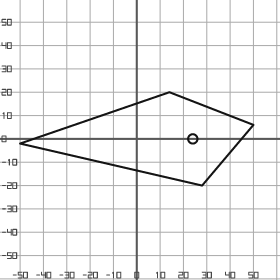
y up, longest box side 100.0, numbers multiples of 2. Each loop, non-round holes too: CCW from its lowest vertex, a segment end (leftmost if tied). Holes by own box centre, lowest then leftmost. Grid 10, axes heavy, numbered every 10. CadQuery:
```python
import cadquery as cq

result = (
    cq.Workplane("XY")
    .moveTo(28.0, -20.0)
    .lineTo(50.0, 6.0)
    .lineTo(14.0, 20.0)
    .lineTo(-50.0, -2.0)
    .close()
    .moveTo(24.0, 0.0)
    .circle(2.0)
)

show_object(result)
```